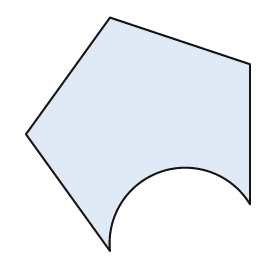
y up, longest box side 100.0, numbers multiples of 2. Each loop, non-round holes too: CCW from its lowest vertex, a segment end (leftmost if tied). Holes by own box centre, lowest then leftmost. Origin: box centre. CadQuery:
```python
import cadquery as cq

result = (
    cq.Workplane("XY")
    .moveTo(-12.0, -50.0)
    .threePointArc((10.0, -16.0), (48.0, -30.0))
    .lineTo(48.0, 30.0)
    .lineTo(-12.0, 50.0)
    .lineTo(-48.0, 0.0)
    .close()
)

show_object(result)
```